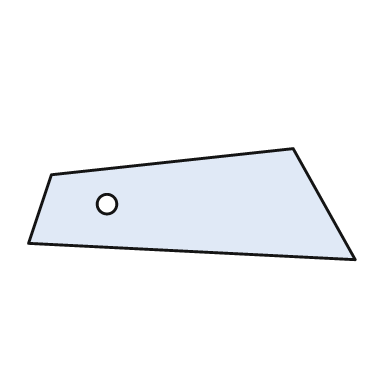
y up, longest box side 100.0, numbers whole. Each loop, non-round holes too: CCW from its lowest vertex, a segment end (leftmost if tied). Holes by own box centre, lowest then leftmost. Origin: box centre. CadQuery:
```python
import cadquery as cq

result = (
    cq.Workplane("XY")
    .moveTo(50.0, -17.0)
    .lineTo(31.0, 17.0)
    .lineTo(-43.0, 9.0)
    .lineTo(-50.0, -12.0)
    .close()
    .moveTo(-26.0, 0.0)
    .circle(3.0)
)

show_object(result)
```